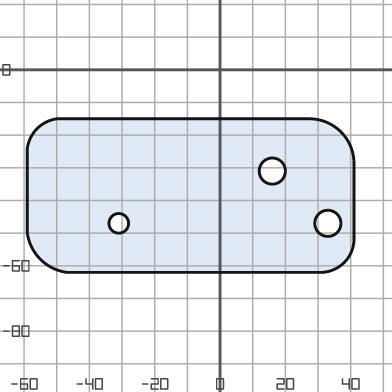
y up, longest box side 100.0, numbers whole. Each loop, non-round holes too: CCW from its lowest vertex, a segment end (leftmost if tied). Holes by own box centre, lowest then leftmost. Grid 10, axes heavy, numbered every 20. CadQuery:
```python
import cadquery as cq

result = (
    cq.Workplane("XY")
    .moveTo(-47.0, -62.0)
    .lineTo(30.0, -62.0)
    .threePointArc((38.0, -59.0), (41.0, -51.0))
    .lineTo(41.0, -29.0)
    .threePointArc((37.0, -19.0), (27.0, -15.0))
    .lineTo(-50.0, -15.0)
    .threePointArc((-56.0, -18.0), (-59.0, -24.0))
    .lineTo(-59.0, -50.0)
    .threePointArc((-55.0, -58.0), (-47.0, -62.0))
    .close()
    .moveTo(-31.0, -47.0)
    .circle(3.0)
    .moveTo(33.0, -47.0)
    .circle(4.0)
    .moveTo(16.0, -31.0)
    .circle(4.0)
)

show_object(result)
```